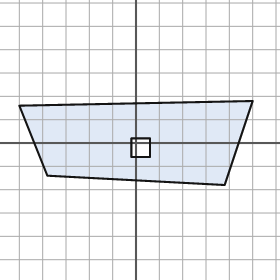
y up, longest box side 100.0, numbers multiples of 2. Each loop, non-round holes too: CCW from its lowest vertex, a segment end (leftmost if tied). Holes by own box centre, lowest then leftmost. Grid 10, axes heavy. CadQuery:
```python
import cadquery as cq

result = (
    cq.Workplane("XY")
    .moveTo(38.0, -18.0)
    .lineTo(50.0, 18.0)
    .lineTo(-50.0, 16.0)
    .lineTo(-38.0, -14.0)
    .close()
    .moveTo(-2.0, -6.0)
    .lineTo(6.0, -6.0)
    .lineTo(6.0, 2.0)
    .lineTo(-2.0, 2.0)
    .close()
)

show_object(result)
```